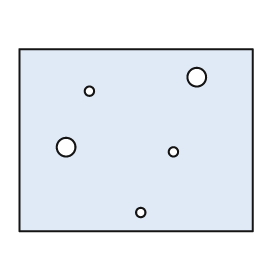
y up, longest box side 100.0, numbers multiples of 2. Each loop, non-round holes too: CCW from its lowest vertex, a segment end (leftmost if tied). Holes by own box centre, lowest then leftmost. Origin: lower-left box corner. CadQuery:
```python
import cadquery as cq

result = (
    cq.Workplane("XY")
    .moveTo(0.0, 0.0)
    .lineTo(100.0, 0.0)
    .lineTo(100.0, 78.0)
    .lineTo(0.0, 78.0)
    .close()
    .moveTo(52.0, 8.0)
    .circle(2.0)
    .moveTo(66.0, 34.0)
    .circle(2.0)
    .moveTo(20.0, 36.0)
    .circle(4.0)
    .moveTo(30.0, 60.0)
    .circle(2.0)
    .moveTo(76.0, 66.0)
    .circle(4.0)
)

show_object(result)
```